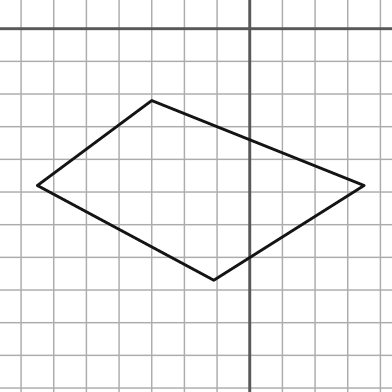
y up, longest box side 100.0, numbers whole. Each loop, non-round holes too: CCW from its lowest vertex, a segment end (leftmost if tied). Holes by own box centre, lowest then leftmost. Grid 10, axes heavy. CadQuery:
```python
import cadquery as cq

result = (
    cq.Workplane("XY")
    .moveTo(-11.0, -77.0)
    .lineTo(35.0, -48.0)
    .lineTo(-30.0, -22.0)
    .lineTo(-65.0, -48.0)
    .close()
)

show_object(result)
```